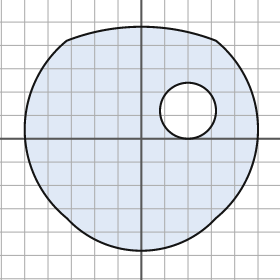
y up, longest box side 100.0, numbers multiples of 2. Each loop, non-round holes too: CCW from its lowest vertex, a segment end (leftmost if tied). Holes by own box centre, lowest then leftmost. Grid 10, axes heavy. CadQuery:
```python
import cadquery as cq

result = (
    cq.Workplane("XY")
    .moveTo(-32.0, -34.0)
    .threePointArc((0.0, -48.0), (32.0, -34.0))
    .threePointArc((50.0, 4.0), (32.0, 42.0))
    .threePointArc((0.0, 48.0), (-32.0, 42.0))
    .threePointArc((-50.0, 4.0), (-32.0, -34.0))
    .close()
    .moveTo(20.0, 12.0)
    .circle(12.0)
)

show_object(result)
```